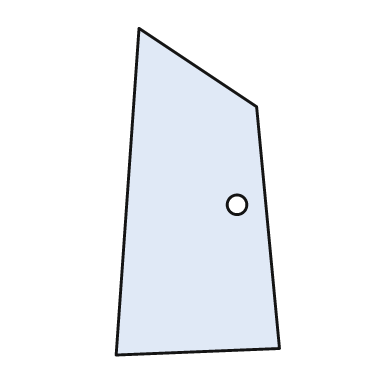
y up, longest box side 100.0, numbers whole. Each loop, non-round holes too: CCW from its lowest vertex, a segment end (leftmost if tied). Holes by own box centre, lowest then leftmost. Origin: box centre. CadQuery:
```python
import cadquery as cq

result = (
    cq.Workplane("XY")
    .moveTo(-25.0, -50.0)
    .lineTo(25.0, -48.0)
    .lineTo(18.0, 26.0)
    .lineTo(-18.0, 50.0)
    .close()
    .moveTo(12.0, -4.0)
    .circle(3.0)
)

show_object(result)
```